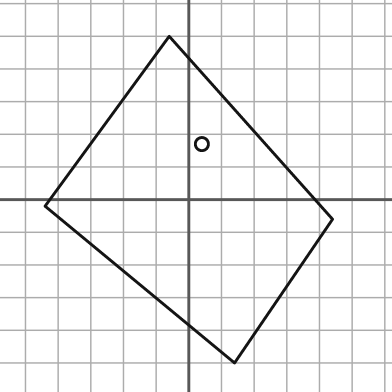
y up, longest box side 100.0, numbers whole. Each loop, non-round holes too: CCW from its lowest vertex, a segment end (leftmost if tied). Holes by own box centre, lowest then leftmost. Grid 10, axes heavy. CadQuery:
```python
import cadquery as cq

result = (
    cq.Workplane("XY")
    .moveTo(14.0, -50.0)
    .lineTo(44.0, -6.0)
    .lineTo(-6.0, 50.0)
    .lineTo(-44.0, -2.0)
    .close()
    .moveTo(4.0, 17.0)
    .circle(2.0)
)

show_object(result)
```